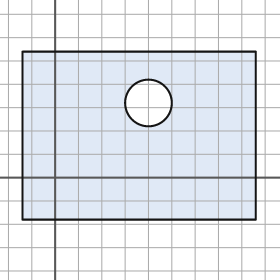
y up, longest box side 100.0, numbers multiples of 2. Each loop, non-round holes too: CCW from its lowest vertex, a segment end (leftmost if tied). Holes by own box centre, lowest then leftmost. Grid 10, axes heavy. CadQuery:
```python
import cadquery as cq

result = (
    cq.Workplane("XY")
    .moveTo(-14.0, -18.0)
    .lineTo(86.0, -18.0)
    .lineTo(86.0, 54.0)
    .lineTo(-14.0, 54.0)
    .close()
    .moveTo(40.0, 32.0)
    .circle(10.0)
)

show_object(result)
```